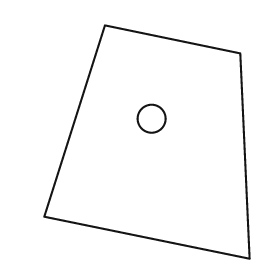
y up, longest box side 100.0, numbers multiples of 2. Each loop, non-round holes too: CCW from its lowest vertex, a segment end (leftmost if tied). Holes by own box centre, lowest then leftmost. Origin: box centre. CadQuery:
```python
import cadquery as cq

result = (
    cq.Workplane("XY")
    .moveTo(44.0, -50.0)
    .lineTo(40.0, 38.0)
    .lineTo(-18.0, 50.0)
    .lineTo(-44.0, -32.0)
    .close()
    .moveTo(2.0, 10.0)
    .circle(6.0)
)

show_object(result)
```